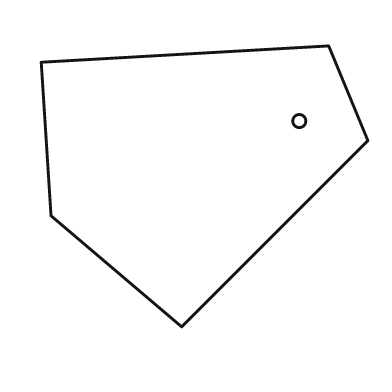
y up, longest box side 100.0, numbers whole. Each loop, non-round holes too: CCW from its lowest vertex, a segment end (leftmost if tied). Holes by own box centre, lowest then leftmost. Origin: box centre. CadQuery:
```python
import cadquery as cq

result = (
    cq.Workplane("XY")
    .moveTo(-7.0, -43.0)
    .lineTo(50.0, 14.0)
    .lineTo(38.0, 43.0)
    .lineTo(-50.0, 38.0)
    .lineTo(-47.0, -9.0)
    .close()
    .moveTo(29.0, 20.0)
    .circle(2.0)
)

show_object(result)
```